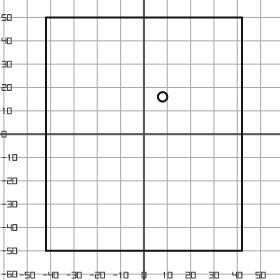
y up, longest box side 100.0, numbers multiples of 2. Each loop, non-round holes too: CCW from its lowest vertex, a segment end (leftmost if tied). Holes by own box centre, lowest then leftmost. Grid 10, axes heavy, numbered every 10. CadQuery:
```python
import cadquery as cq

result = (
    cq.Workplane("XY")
    .moveTo(-42.0, -50.0)
    .lineTo(42.0, -50.0)
    .lineTo(42.0, 50.0)
    .lineTo(-42.0, 50.0)
    .close()
    .moveTo(8.0, 16.0)
    .circle(2.0)
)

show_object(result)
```